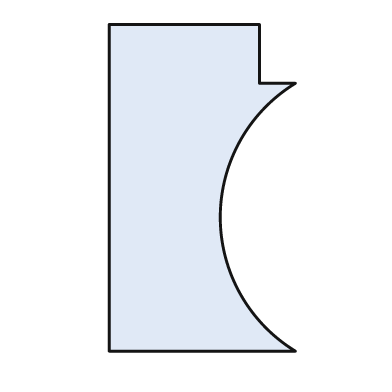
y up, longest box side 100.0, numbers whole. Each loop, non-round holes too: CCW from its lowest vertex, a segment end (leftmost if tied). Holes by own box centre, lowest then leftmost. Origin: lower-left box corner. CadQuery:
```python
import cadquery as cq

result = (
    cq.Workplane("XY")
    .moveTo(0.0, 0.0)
    .lineTo(57.0, 0.0)
    .threePointArc((34.0, 41.0), (57.0, 82.0))
    .lineTo(46.0, 82.0)
    .lineTo(46.0, 100.0)
    .lineTo(0.0, 100.0)
    .close()
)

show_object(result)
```